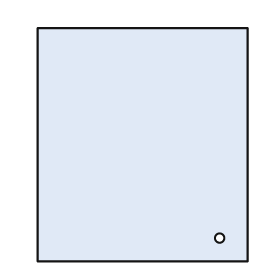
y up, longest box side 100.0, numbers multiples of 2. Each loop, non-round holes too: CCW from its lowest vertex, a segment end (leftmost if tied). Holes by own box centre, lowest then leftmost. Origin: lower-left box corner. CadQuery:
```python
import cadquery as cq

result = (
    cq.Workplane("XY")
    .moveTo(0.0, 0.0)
    .lineTo(90.0, 0.0)
    .lineTo(90.0, 100.0)
    .lineTo(0.0, 100.0)
    .close()
    .moveTo(78.0, 10.0)
    .circle(2.0)
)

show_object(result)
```